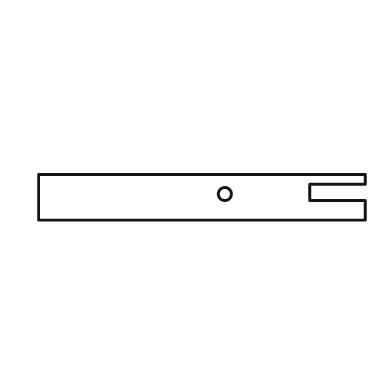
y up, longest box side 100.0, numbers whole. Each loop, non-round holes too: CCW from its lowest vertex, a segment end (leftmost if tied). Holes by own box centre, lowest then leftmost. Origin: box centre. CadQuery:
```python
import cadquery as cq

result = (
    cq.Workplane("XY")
    .moveTo(-50.0, -7.0)
    .lineTo(50.0, -7.0)
    .lineTo(50.0, -1.0)
    .lineTo(33.0, -1.0)
    .lineTo(33.0, 4.0)
    .lineTo(50.0, 4.0)
    .lineTo(50.0, 7.0)
    .lineTo(-50.0, 7.0)
    .close()
    .moveTo(7.0, 1.0)
    .circle(2.0)
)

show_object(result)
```